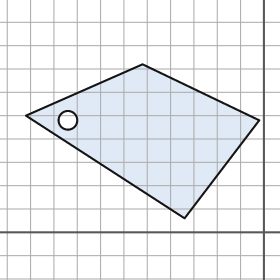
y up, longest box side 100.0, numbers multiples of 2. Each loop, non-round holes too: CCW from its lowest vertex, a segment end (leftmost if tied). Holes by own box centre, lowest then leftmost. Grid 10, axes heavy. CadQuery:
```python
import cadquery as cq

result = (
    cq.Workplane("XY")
    .moveTo(-34.0, 6.0)
    .lineTo(-2.0, 48.0)
    .lineTo(-52.0, 72.0)
    .lineTo(-102.0, 50.0)
    .close()
    .moveTo(-84.0, 48.0)
    .circle(4.0)
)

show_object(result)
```